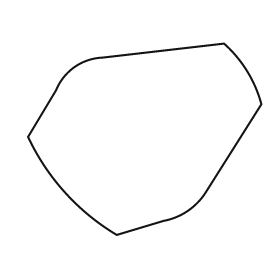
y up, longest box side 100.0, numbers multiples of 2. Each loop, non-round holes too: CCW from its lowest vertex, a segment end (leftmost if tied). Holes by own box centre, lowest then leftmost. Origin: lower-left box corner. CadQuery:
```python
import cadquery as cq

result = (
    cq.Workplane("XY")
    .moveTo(38.0, 0.0)
    .lineTo(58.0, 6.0)
    .threePointArc((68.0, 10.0), (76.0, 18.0))
    .lineTo(100.0, 56.0)
    .threePointArc((94.0, 70.0), (84.0, 82.0))
    .lineTo(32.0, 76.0)
    .threePointArc((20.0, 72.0), (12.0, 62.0))
    .lineTo(0.0, 42.0)
    .threePointArc((16.0, 18.0), (38.0, 0.0))
    .close()
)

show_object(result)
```